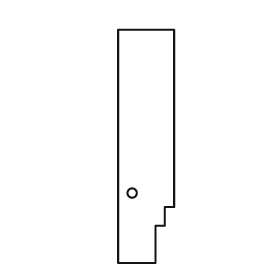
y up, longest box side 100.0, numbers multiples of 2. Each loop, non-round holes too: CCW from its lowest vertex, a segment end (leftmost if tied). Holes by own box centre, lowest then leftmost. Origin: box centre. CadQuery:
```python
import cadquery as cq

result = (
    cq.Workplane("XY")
    .moveTo(-12.0, -50.0)
    .lineTo(4.0, -50.0)
    .lineTo(4.0, -34.0)
    .lineTo(8.0, -34.0)
    .lineTo(8.0, -26.0)
    .lineTo(12.0, -26.0)
    .lineTo(12.0, 50.0)
    .lineTo(-12.0, 50.0)
    .close()
    .moveTo(-6.0, -20.0)
    .circle(2.0)
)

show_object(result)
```